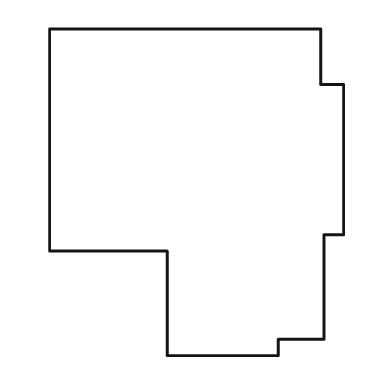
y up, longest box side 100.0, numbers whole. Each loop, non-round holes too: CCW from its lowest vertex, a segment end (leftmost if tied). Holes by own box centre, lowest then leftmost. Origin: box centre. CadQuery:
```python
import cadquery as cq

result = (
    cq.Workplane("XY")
    .moveTo(-9.0, -50.0)
    .lineTo(25.0, -50.0)
    .lineTo(25.0, -45.0)
    .lineTo(39.0, -45.0)
    .lineTo(39.0, -13.0)
    .lineTo(45.0, -13.0)
    .lineTo(45.0, 33.0)
    .lineTo(38.0, 33.0)
    .lineTo(38.0, 50.0)
    .lineTo(-45.0, 50.0)
    .lineTo(-45.0, -18.0)
    .lineTo(-9.0, -18.0)
    .close()
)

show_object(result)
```